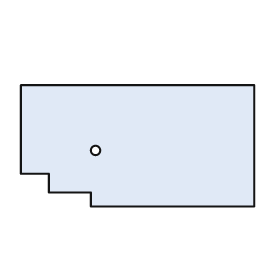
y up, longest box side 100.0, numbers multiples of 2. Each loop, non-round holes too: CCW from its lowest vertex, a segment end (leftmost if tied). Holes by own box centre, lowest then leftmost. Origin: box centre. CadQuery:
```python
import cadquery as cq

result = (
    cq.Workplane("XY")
    .moveTo(-20.0, -26.0)
    .lineTo(50.0, -26.0)
    .lineTo(50.0, 26.0)
    .lineTo(-50.0, 26.0)
    .lineTo(-50.0, -12.0)
    .lineTo(-38.0, -12.0)
    .lineTo(-38.0, -20.0)
    .lineTo(-20.0, -20.0)
    .close()
    .moveTo(-18.0, -2.0)
    .circle(2.0)
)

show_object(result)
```